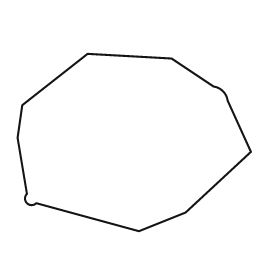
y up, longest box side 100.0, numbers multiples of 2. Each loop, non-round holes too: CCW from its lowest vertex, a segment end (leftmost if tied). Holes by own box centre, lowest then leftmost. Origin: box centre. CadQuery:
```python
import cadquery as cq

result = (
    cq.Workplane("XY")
    .moveTo(2.0, -38.0)
    .lineTo(22.0, -30.0)
    .lineTo(50.0, -4.0)
    .lineTo(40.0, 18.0)
    .threePointArc((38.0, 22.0), (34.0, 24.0))
    .lineTo(16.0, 36.0)
    .lineTo(-20.0, 38.0)
    .lineTo(-48.0, 16.0)
    .lineTo(-50.0, 2.0)
    .lineTo(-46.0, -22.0)
    .threePointArc((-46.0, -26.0), (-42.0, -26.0))
    .close()
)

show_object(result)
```